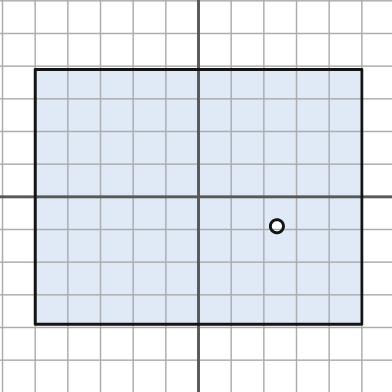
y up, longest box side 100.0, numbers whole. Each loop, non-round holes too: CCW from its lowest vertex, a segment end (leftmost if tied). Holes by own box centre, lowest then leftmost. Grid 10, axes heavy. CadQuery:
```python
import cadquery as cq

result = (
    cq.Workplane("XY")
    .moveTo(-50.0, -39.0)
    .lineTo(50.0, -39.0)
    .lineTo(50.0, 39.0)
    .lineTo(-50.0, 39.0)
    .close()
    .moveTo(24.0, -9.0)
    .circle(2.0)
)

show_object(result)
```